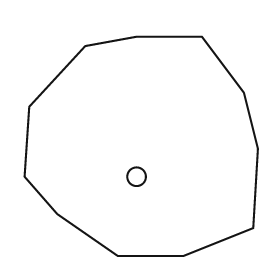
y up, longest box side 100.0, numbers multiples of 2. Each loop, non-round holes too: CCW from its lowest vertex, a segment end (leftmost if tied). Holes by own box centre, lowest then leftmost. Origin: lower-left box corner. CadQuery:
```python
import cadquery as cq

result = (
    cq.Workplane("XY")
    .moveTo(40.0, 0.0)
    .lineTo(68.0, 0.0)
    .lineTo(98.0, 12.0)
    .lineTo(100.0, 46.0)
    .lineTo(94.0, 70.0)
    .lineTo(76.0, 94.0)
    .lineTo(48.0, 94.0)
    .lineTo(26.0, 90.0)
    .lineTo(2.0, 64.0)
    .lineTo(0.0, 34.0)
    .lineTo(14.0, 18.0)
    .close()
    .moveTo(48.0, 34.0)
    .circle(4.0)
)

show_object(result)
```